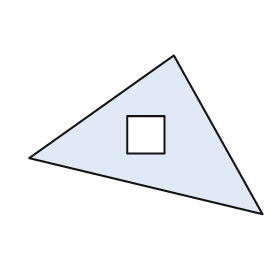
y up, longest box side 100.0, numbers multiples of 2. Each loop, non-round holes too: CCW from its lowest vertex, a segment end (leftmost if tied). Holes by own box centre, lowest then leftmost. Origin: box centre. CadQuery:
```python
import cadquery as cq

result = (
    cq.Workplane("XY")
    .moveTo(50.0, -34.0)
    .lineTo(12.0, 34.0)
    .lineTo(-50.0, -10.0)
    .close()
    .moveTo(-8.0, -8.0)
    .lineTo(8.0, -8.0)
    .lineTo(8.0, 8.0)
    .lineTo(-8.0, 8.0)
    .close()
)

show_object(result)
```